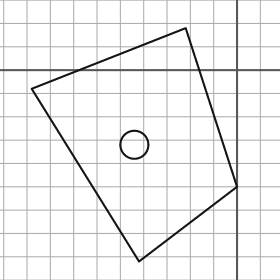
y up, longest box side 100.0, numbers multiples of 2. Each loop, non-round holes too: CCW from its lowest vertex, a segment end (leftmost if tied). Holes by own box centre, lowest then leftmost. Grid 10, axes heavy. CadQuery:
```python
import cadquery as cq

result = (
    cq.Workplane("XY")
    .moveTo(-42.0, -82.0)
    .lineTo(0.0, -50.0)
    .lineTo(-22.0, 18.0)
    .lineTo(-88.0, -8.0)
    .close()
    .moveTo(-44.0, -32.0)
    .circle(6.0)
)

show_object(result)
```